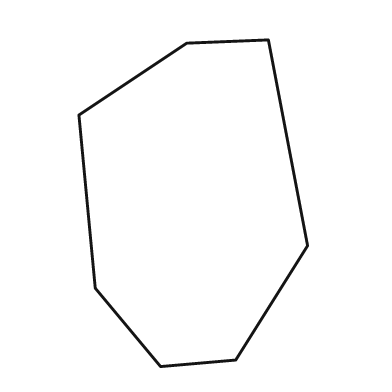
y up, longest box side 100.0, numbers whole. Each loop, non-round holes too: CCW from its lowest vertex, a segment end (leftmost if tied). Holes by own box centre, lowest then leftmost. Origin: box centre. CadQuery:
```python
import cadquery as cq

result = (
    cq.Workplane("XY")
    .moveTo(-10.0, -50.0)
    .lineTo(13.0, -48.0)
    .lineTo(35.0, -13.0)
    .lineTo(23.0, 50.0)
    .lineTo(-2.0, 49.0)
    .lineTo(-35.0, 27.0)
    .lineTo(-30.0, -26.0)
    .close()
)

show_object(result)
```